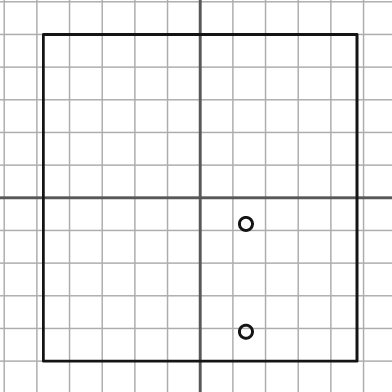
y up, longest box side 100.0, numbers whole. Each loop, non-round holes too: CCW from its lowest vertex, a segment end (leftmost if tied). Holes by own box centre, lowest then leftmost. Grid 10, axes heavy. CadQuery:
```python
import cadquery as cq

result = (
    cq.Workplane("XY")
    .moveTo(-48.0, -50.0)
    .lineTo(48.0, -50.0)
    .lineTo(48.0, 50.0)
    .lineTo(-48.0, 50.0)
    .close()
    .moveTo(14.0, -41.0)
    .circle(2.0)
    .moveTo(14.0, -8.0)
    .circle(2.0)
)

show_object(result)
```